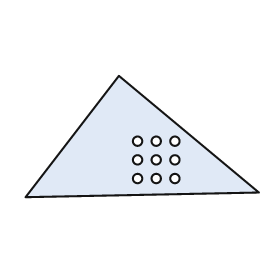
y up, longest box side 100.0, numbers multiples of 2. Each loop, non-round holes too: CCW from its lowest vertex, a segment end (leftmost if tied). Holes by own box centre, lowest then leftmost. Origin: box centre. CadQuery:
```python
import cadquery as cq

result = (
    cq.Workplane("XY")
    .moveTo(-50.0, -26.0)
    .lineTo(50.0, -24.0)
    .lineTo(-10.0, 26.0)
    .close()
    .moveTo(-2.0, -18.0)
    .circle(2.0)
    .moveTo(6.0, -18.0)
    .circle(2.0)
    .moveTo(14.0, -18.0)
    .circle(2.0)
    .moveTo(-2.0, -10.0)
    .circle(2.0)
    .moveTo(6.0, -10.0)
    .circle(2.0)
    .moveTo(14.0, -10.0)
    .circle(2.0)
    .moveTo(-2.0, -2.0)
    .circle(2.0)
    .moveTo(6.0, -2.0)
    .circle(2.0)
    .moveTo(14.0, -2.0)
    .circle(2.0)
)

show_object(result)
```